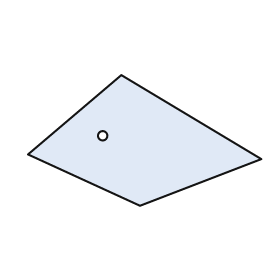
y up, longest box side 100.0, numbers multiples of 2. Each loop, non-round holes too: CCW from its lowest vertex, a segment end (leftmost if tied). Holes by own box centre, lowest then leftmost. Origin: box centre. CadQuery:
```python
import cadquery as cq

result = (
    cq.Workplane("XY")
    .moveTo(-2.0, -28.0)
    .lineTo(50.0, -8.0)
    .lineTo(-10.0, 28.0)
    .lineTo(-50.0, -6.0)
    .close()
    .moveTo(-18.0, 2.0)
    .circle(2.0)
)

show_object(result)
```